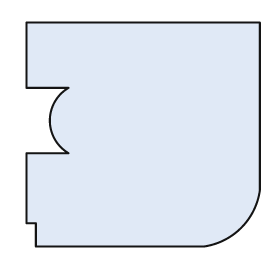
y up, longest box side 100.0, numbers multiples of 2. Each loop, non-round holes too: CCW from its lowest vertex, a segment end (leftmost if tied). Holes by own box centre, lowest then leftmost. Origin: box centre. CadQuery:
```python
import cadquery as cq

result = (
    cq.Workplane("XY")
    .moveTo(-46.0, -48.0)
    .lineTo(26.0, -48.0)
    .threePointArc((42.0, -40.0), (50.0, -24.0))
    .lineTo(50.0, 48.0)
    .lineTo(-50.0, 48.0)
    .lineTo(-50.0, 20.0)
    .lineTo(-32.0, 20.0)
    .threePointArc((-40.0, 6.0), (-32.0, -8.0))
    .lineTo(-50.0, -8.0)
    .lineTo(-50.0, -38.0)
    .lineTo(-46.0, -38.0)
    .close()
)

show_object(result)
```